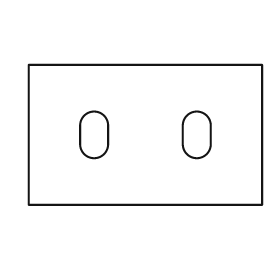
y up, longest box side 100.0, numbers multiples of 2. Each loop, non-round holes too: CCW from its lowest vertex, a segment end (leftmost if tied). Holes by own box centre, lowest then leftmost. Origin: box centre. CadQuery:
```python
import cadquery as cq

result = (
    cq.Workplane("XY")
    .moveTo(-50.0, -30.0)
    .lineTo(50.0, -30.0)
    .lineTo(50.0, 30.0)
    .lineTo(-50.0, 30.0)
    .close()
    .moveTo(-28.0, -4.0)
    .threePointArc((-22.0, -10.0), (-16.0, -4.0))
    .lineTo(-16.0, 4.0)
    .threePointArc((-22.0, 10.0), (-28.0, 4.0))
    .close()
    .moveTo(16.0, -4.0)
    .threePointArc((22.0, -10.0), (28.0, -4.0))
    .lineTo(28.0, 4.0)
    .threePointArc((22.0, 10.0), (16.0, 4.0))
    .close()
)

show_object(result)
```